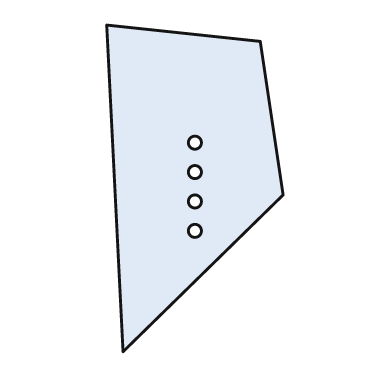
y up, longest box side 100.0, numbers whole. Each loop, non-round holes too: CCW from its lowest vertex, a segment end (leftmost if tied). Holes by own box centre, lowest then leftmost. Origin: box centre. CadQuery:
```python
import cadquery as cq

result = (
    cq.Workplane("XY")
    .moveTo(-22.0, -50.0)
    .lineTo(27.0, -2.0)
    .lineTo(20.0, 45.0)
    .lineTo(-27.0, 50.0)
    .close()
    .moveTo(0.0, -13.0)
    .circle(2.0)
    .moveTo(0.0, -4.0)
    .circle(2.0)
    .moveTo(0.0, 5.0)
    .circle(2.0)
    .moveTo(0.0, 14.0)
    .circle(2.0)
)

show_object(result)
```